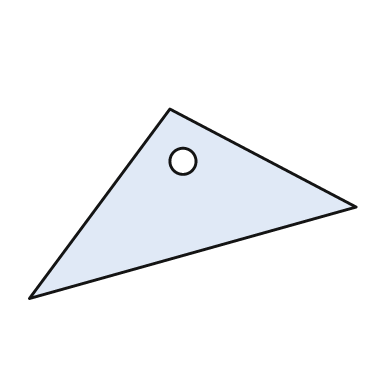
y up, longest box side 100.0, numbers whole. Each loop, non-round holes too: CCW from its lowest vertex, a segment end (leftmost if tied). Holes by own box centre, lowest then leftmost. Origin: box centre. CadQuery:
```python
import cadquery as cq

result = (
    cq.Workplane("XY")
    .moveTo(-50.0, -29.0)
    .lineTo(50.0, -1.0)
    .lineTo(-7.0, 29.0)
    .close()
    .moveTo(-3.0, 13.0)
    .circle(4.0)
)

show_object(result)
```